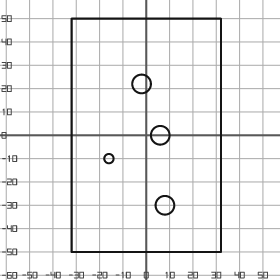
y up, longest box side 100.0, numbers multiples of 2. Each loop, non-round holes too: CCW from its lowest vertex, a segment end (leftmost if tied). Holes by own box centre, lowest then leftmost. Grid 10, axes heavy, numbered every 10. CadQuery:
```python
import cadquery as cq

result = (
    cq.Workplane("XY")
    .moveTo(-32.0, -50.0)
    .lineTo(32.0, -50.0)
    .lineTo(32.0, 50.0)
    .lineTo(-32.0, 50.0)
    .close()
    .moveTo(8.0, -30.0)
    .circle(4.0)
    .moveTo(-16.0, -10.0)
    .circle(2.0)
    .moveTo(6.0, 0.0)
    .circle(4.0)
    .moveTo(-2.0, 22.0)
    .circle(4.0)
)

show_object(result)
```